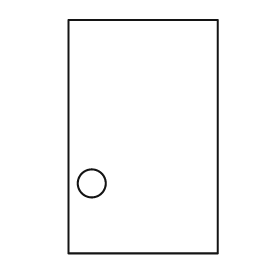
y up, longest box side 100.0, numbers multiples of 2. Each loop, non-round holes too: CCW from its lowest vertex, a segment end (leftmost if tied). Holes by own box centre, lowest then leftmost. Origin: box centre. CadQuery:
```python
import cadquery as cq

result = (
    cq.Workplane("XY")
    .moveTo(-32.0, -50.0)
    .lineTo(32.0, -50.0)
    .lineTo(32.0, 50.0)
    .lineTo(-32.0, 50.0)
    .close()
    .moveTo(-22.0, -20.0)
    .circle(6.0)
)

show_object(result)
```